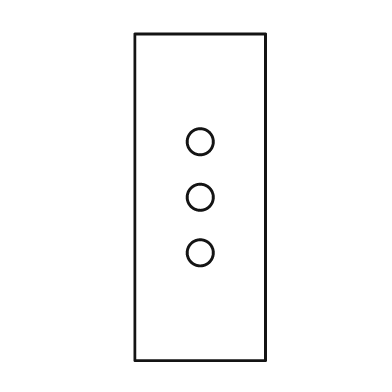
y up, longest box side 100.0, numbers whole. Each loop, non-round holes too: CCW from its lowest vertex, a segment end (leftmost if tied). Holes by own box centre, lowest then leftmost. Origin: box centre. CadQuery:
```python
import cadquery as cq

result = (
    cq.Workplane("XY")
    .moveTo(-20.0, -50.0)
    .lineTo(20.0, -50.0)
    .lineTo(20.0, 50.0)
    .lineTo(-20.0, 50.0)
    .close()
    .moveTo(0.0, -17.0)
    .circle(4.0)
    .moveTo(0.0, 0.0)
    .circle(4.0)
    .moveTo(0.0, 17.0)
    .circle(4.0)
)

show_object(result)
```